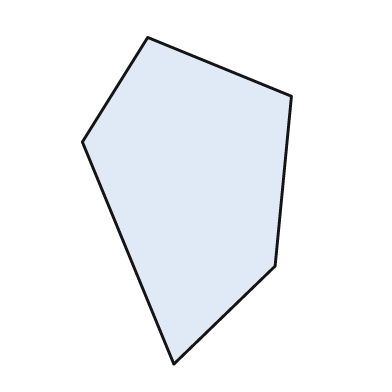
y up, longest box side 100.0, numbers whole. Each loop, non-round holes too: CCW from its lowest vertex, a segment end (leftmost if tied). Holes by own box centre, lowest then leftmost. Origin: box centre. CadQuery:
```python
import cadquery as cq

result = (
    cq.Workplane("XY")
    .moveTo(-4.0, -50.0)
    .lineTo(27.0, -20.0)
    .lineTo(32.0, 32.0)
    .lineTo(-12.0, 50.0)
    .lineTo(-32.0, 18.0)
    .close()
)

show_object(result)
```